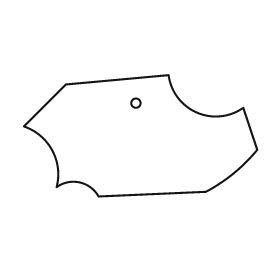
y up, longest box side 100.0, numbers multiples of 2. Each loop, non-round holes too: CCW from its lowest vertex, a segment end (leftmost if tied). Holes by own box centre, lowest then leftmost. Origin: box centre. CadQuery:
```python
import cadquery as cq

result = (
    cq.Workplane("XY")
    .moveTo(-18.0, -26.0)
    .lineTo(28.0, -24.0)
    .threePointArc((40.0, -16.0), (50.0, -6.0))
    .lineTo(44.0, 12.0)
    .threePointArc((24.0, 10.0), (12.0, 26.0))
    .lineTo(-32.0, 22.0)
    .lineTo(-50.0, 4.0)
    .threePointArc((-38.0, -6.0), (-36.0, -22.0))
    .threePointArc((-26.0, -20.0), (-18.0, -26.0))
    .close()
    .moveTo(-2.0, 14.0)
    .circle(2.0)
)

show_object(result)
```